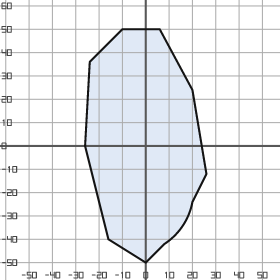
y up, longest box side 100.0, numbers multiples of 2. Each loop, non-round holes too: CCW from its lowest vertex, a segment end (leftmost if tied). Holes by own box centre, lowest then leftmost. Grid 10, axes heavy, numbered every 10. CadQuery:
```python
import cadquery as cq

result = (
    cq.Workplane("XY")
    .moveTo(0.0, -50.0)
    .lineTo(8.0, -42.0)
    .threePointArc((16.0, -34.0), (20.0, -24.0))
    .lineTo(26.0, -12.0)
    .lineTo(20.0, 24.0)
    .lineTo(6.0, 50.0)
    .lineTo(-10.0, 50.0)
    .lineTo(-24.0, 36.0)
    .lineTo(-26.0, 0.0)
    .lineTo(-16.0, -40.0)
    .close()
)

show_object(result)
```